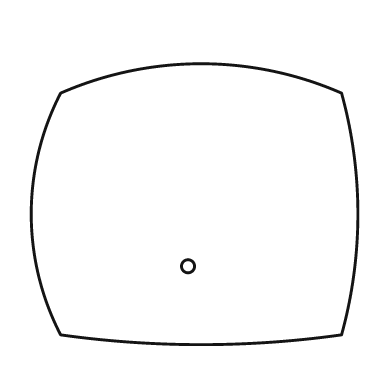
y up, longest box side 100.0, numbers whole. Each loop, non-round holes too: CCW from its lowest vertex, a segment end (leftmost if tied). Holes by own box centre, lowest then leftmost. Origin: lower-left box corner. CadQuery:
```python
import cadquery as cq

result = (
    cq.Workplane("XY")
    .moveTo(9.0, 3.0)
    .threePointArc((52.0, 0.0), (95.0, 3.0))
    .threePointArc((100.0, 40.0), (95.0, 77.0))
    .threePointArc((52.0, 86.0), (9.0, 77.0))
    .threePointArc((0.0, 40.0), (9.0, 3.0))
    .close()
    .moveTo(48.0, 24.0)
    .circle(2.0)
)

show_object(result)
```